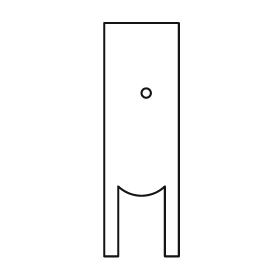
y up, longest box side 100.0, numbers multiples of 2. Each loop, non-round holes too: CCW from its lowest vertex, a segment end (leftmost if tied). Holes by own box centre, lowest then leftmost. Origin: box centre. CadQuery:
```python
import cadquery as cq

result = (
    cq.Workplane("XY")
    .moveTo(-16.0, -50.0)
    .lineTo(-10.0, -50.0)
    .lineTo(-10.0, -20.0)
    .threePointArc((0.0, -24.0), (10.0, -20.0))
    .lineTo(10.0, -50.0)
    .lineTo(16.0, -50.0)
    .lineTo(16.0, 50.0)
    .lineTo(-16.0, 50.0)
    .close()
    .moveTo(2.0, 20.0)
    .circle(2.0)
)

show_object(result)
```